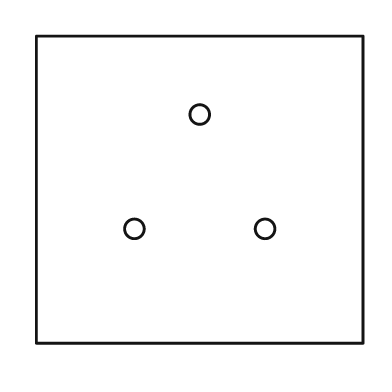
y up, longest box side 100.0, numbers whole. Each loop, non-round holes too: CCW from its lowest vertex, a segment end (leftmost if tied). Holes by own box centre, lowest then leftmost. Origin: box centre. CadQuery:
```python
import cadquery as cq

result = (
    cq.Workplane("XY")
    .moveTo(-50.0, -47.0)
    .lineTo(50.0, -47.0)
    .lineTo(50.0, 47.0)
    .lineTo(-50.0, 47.0)
    .close()
    .moveTo(-20.0, -12.0)
    .circle(3.0)
    .moveTo(20.0, -12.0)
    .circle(3.0)
    .moveTo(0.0, 23.0)
    .circle(3.0)
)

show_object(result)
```